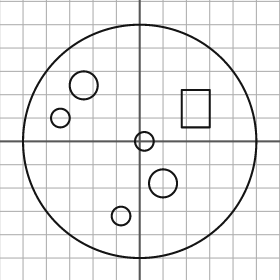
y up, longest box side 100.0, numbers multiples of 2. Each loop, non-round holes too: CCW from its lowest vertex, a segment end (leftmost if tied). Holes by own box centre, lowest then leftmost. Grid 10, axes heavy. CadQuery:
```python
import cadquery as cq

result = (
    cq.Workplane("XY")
    .moveTo(0.0, 0.0)
    .circle(50.0)
    .moveTo(-8.0, -32.0)
    .circle(4.0)
    .moveTo(10.0, -18.0)
    .circle(6.0)
    .moveTo(2.0, 0.0)
    .circle(4.0)
    .moveTo(-34.0, 10.0)
    .circle(4.0)
    .moveTo(18.0, 6.0)
    .lineTo(30.0, 6.0)
    .lineTo(30.0, 22.0)
    .lineTo(18.0, 22.0)
    .close()
    .moveTo(-24.0, 24.0)
    .circle(6.0)
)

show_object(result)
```